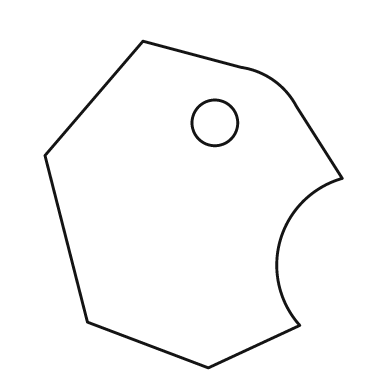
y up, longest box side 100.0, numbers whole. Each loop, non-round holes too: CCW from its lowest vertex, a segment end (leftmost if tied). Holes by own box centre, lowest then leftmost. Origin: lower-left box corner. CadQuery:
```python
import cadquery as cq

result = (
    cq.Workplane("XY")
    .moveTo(50.0, 0.0)
    .lineTo(78.0, 13.0)
    .threePointArc((72.0, 39.0), (91.0, 58.0))
    .lineTo(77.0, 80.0)
    .threePointArc((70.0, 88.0), (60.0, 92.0))
    .lineTo(30.0, 100.0)
    .lineTo(0.0, 65.0)
    .lineTo(13.0, 14.0)
    .close()
    .moveTo(52.0, 75.0)
    .circle(7.0)
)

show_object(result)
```